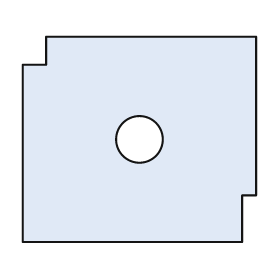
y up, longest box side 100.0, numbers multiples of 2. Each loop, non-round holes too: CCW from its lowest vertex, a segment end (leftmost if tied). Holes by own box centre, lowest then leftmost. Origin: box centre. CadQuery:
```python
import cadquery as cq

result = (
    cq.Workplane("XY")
    .moveTo(-50.0, -44.0)
    .lineTo(44.0, -44.0)
    .lineTo(44.0, -24.0)
    .lineTo(50.0, -24.0)
    .lineTo(50.0, 44.0)
    .lineTo(-40.0, 44.0)
    .lineTo(-40.0, 32.0)
    .lineTo(-50.0, 32.0)
    .close()
    .moveTo(0.0, 0.0)
    .circle(10.0)
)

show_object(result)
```